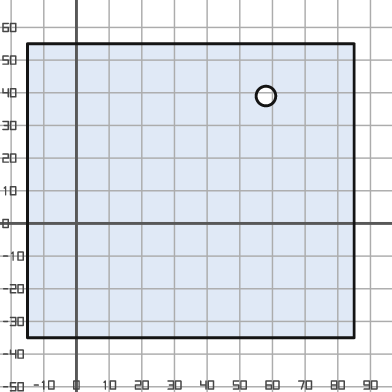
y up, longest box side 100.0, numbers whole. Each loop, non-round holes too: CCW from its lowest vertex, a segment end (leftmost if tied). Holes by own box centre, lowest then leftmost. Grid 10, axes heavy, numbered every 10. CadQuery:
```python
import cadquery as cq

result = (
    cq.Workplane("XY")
    .moveTo(-15.0, -35.0)
    .lineTo(85.0, -35.0)
    .lineTo(85.0, 55.0)
    .lineTo(-15.0, 55.0)
    .close()
    .moveTo(58.0, 39.0)
    .circle(3.0)
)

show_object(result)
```